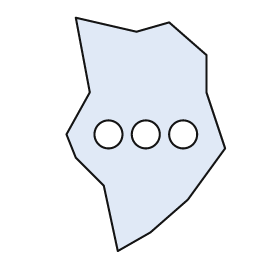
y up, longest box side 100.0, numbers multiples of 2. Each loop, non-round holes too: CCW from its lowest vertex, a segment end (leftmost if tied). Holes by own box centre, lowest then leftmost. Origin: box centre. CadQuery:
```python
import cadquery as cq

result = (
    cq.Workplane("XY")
    .moveTo(-12.0, -50.0)
    .lineTo(2.0, -42.0)
    .lineTo(18.0, -28.0)
    .lineTo(34.0, -6.0)
    .lineTo(26.0, 18.0)
    .lineTo(26.0, 34.0)
    .lineTo(10.0, 48.0)
    .lineTo(-4.0, 44.0)
    .lineTo(-30.0, 50.0)
    .lineTo(-24.0, 18.0)
    .lineTo(-34.0, 0.0)
    .lineTo(-30.0, -10.0)
    .lineTo(-18.0, -22.0)
    .close()
    .moveTo(-16.0, 0.0)
    .circle(6.0)
    .moveTo(0.0, 0.0)
    .circle(6.0)
    .moveTo(16.0, 0.0)
    .circle(6.0)
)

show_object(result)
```